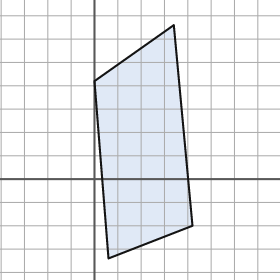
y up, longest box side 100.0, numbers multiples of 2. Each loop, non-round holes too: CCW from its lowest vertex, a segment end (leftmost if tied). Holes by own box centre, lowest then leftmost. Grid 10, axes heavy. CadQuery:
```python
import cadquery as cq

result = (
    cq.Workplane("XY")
    .moveTo(6.0, -34.0)
    .lineTo(42.0, -20.0)
    .lineTo(34.0, 66.0)
    .lineTo(0.0, 42.0)
    .close()
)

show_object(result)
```